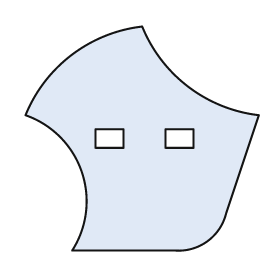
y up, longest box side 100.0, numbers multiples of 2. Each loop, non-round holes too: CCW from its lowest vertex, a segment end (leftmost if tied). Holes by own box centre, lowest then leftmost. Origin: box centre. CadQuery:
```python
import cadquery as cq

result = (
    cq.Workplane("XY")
    .moveTo(-30.0, -48.0)
    .lineTo(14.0, -48.0)
    .threePointArc((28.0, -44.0), (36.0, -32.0))
    .lineTo(50.0, 10.0)
    .threePointArc((20.0, 22.0), (0.0, 48.0))
    .threePointArc((-30.0, 36.0), (-50.0, 10.0))
    .threePointArc((-26.0, -14.0), (-30.0, -48.0))
    .close()
    .moveTo(-20.0, -4.0)
    .lineTo(-8.0, -4.0)
    .lineTo(-8.0, 4.0)
    .lineTo(-20.0, 4.0)
    .close()
    .moveTo(10.0, -4.0)
    .lineTo(22.0, -4.0)
    .lineTo(22.0, 4.0)
    .lineTo(10.0, 4.0)
    .close()
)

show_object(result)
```